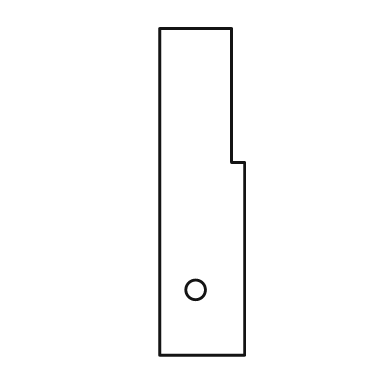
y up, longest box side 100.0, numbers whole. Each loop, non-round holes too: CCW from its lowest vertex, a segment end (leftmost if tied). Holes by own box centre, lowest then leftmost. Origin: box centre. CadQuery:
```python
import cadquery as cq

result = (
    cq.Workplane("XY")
    .moveTo(-13.0, -50.0)
    .lineTo(13.0, -50.0)
    .lineTo(13.0, 9.0)
    .lineTo(9.0, 9.0)
    .lineTo(9.0, 50.0)
    .lineTo(-13.0, 50.0)
    .close()
    .moveTo(-2.0, -30.0)
    .circle(3.0)
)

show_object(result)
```